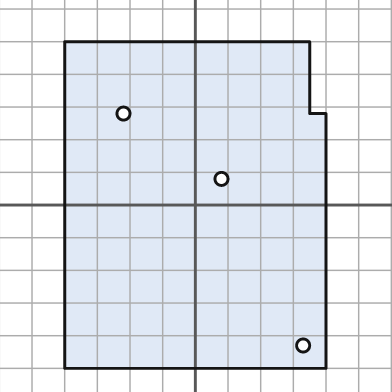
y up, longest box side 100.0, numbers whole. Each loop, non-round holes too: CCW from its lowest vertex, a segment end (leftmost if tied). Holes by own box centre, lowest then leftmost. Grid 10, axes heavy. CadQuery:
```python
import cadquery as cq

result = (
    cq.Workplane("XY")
    .moveTo(-40.0, -50.0)
    .lineTo(40.0, -50.0)
    .lineTo(40.0, 28.0)
    .lineTo(35.0, 28.0)
    .lineTo(35.0, 50.0)
    .lineTo(-40.0, 50.0)
    .close()
    .moveTo(33.0, -43.0)
    .circle(2.0)
    .moveTo(8.0, 8.0)
    .circle(2.0)
    .moveTo(-22.0, 28.0)
    .circle(2.0)
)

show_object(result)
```